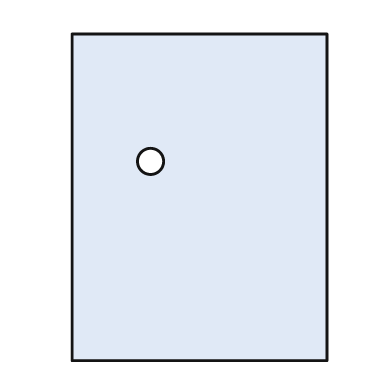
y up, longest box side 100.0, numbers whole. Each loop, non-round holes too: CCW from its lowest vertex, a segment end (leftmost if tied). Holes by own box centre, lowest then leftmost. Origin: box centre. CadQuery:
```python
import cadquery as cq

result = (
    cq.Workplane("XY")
    .moveTo(-39.0, -50.0)
    .lineTo(39.0, -50.0)
    .lineTo(39.0, 50.0)
    .lineTo(-39.0, 50.0)
    .close()
    .moveTo(-15.0, 11.0)
    .circle(4.0)
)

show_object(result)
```